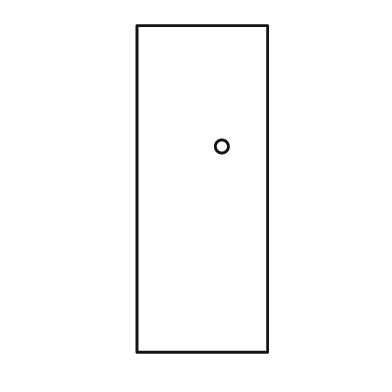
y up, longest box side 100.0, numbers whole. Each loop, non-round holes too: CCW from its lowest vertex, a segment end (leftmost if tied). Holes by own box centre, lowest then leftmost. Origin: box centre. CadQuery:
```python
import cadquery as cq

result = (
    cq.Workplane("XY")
    .moveTo(-20.0, -50.0)
    .lineTo(20.0, -50.0)
    .lineTo(20.0, 50.0)
    .lineTo(-20.0, 50.0)
    .close()
    .moveTo(6.0, 13.0)
    .circle(2.0)
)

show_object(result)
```